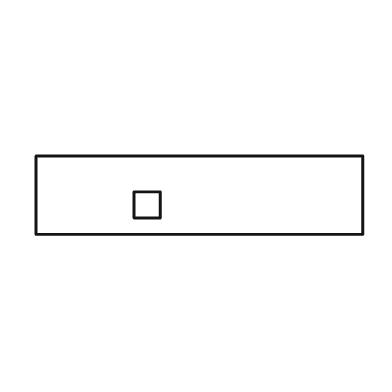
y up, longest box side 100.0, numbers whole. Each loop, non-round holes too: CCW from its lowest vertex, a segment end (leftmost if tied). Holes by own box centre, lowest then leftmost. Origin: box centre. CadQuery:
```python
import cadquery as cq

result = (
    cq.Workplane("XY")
    .moveTo(-50.0, -12.0)
    .lineTo(50.0, -12.0)
    .lineTo(50.0, 12.0)
    .lineTo(-50.0, 12.0)
    .close()
    .moveTo(-20.0, -7.0)
    .lineTo(-12.0, -7.0)
    .lineTo(-12.0, 1.0)
    .lineTo(-20.0, 1.0)
    .close()
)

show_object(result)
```